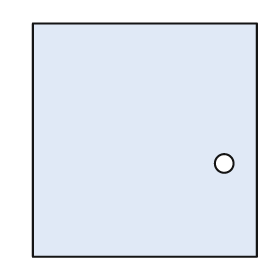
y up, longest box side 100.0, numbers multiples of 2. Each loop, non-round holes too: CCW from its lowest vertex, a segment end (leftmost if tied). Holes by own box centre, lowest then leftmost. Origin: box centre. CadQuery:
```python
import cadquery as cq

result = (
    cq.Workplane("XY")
    .moveTo(-48.0, -50.0)
    .lineTo(48.0, -50.0)
    .lineTo(48.0, 50.0)
    .lineTo(-48.0, 50.0)
    .close()
    .moveTo(34.0, -10.0)
    .circle(4.0)
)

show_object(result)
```